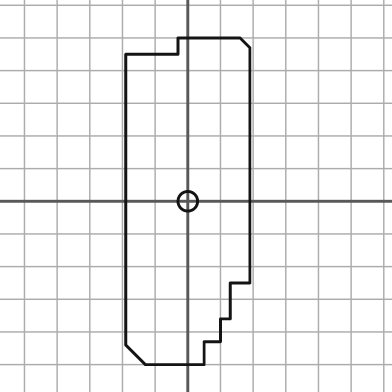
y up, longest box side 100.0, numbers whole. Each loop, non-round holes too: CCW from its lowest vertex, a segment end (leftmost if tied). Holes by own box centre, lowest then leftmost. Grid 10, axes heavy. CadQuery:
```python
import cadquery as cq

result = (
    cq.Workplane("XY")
    .moveTo(-13.0, -50.0)
    .lineTo(5.0, -50.0)
    .lineTo(5.0, -43.0)
    .lineTo(10.0, -43.0)
    .lineTo(10.0, -36.0)
    .lineTo(13.0, -36.0)
    .lineTo(13.0, -25.0)
    .lineTo(19.0, -25.0)
    .lineTo(19.0, 47.0)
    .lineTo(16.0, 50.0)
    .lineTo(-3.0, 50.0)
    .lineTo(-3.0, 45.0)
    .lineTo(-19.0, 45.0)
    .lineTo(-19.0, -44.0)
    .close()
    .moveTo(0.0, 0.0)
    .circle(3.0)
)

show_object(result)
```